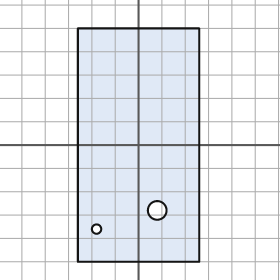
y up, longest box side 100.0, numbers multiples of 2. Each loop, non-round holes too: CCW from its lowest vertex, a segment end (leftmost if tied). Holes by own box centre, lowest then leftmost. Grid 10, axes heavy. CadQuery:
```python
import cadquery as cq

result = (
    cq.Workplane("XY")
    .moveTo(-26.0, -50.0)
    .lineTo(26.0, -50.0)
    .lineTo(26.0, 50.0)
    .lineTo(-26.0, 50.0)
    .close()
    .moveTo(-18.0, -36.0)
    .circle(2.0)
    .moveTo(8.0, -28.0)
    .circle(4.0)
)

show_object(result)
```